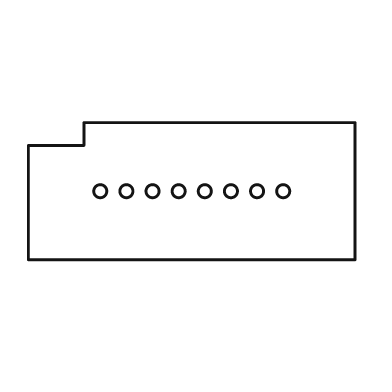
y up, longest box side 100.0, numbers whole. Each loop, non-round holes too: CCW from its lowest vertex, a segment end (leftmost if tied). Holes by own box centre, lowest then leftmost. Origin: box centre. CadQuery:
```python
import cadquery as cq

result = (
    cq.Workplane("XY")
    .moveTo(-50.0, -21.0)
    .lineTo(50.0, -21.0)
    .lineTo(50.0, 21.0)
    .lineTo(-33.0, 21.0)
    .lineTo(-33.0, 14.0)
    .lineTo(-50.0, 14.0)
    .close()
    .moveTo(-28.0, 0.0)
    .circle(2.0)
    .moveTo(-20.0, 0.0)
    .circle(2.0)
    .moveTo(-12.0, 0.0)
    .circle(2.0)
    .moveTo(-4.0, 0.0)
    .circle(2.0)
    .moveTo(4.0, 0.0)
    .circle(2.0)
    .moveTo(12.0, 0.0)
    .circle(2.0)
    .moveTo(20.0, 0.0)
    .circle(2.0)
    .moveTo(28.0, 0.0)
    .circle(2.0)
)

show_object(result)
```